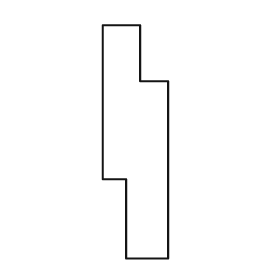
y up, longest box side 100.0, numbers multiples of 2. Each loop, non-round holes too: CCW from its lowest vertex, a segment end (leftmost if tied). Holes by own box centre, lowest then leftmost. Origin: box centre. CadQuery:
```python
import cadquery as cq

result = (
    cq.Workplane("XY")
    .moveTo(-4.0, -50.0)
    .lineTo(14.0, -50.0)
    .lineTo(14.0, 26.0)
    .lineTo(2.0, 26.0)
    .lineTo(2.0, 50.0)
    .lineTo(-14.0, 50.0)
    .lineTo(-14.0, -16.0)
    .lineTo(-4.0, -16.0)
    .close()
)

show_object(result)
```